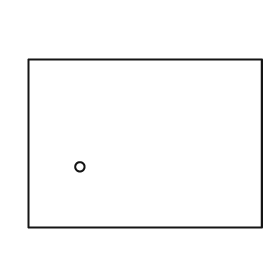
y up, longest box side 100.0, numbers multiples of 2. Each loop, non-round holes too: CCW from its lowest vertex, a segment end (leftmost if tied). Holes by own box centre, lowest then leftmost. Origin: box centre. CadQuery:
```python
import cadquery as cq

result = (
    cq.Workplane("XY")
    .moveTo(-50.0, -36.0)
    .lineTo(50.0, -36.0)
    .lineTo(50.0, 36.0)
    .lineTo(-50.0, 36.0)
    .close()
    .moveTo(-28.0, -10.0)
    .circle(2.0)
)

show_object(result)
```